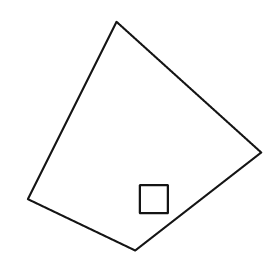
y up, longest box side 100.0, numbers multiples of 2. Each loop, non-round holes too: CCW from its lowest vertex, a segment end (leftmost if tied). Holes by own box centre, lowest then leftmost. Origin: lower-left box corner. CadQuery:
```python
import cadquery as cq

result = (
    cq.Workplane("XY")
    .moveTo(46.0, 0.0)
    .lineTo(100.0, 42.0)
    .lineTo(38.0, 98.0)
    .lineTo(0.0, 22.0)
    .close()
    .moveTo(48.0, 16.0)
    .lineTo(60.0, 16.0)
    .lineTo(60.0, 28.0)
    .lineTo(48.0, 28.0)
    .close()
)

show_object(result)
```